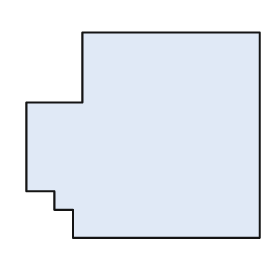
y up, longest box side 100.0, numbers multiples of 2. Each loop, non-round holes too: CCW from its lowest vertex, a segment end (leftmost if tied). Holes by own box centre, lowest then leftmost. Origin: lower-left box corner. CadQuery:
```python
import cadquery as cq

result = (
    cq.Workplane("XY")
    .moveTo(20.0, 0.0)
    .lineTo(100.0, 0.0)
    .lineTo(100.0, 88.0)
    .lineTo(24.0, 88.0)
    .lineTo(24.0, 58.0)
    .lineTo(0.0, 58.0)
    .lineTo(0.0, 20.0)
    .lineTo(12.0, 20.0)
    .lineTo(12.0, 12.0)
    .lineTo(20.0, 12.0)
    .close()
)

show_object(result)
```